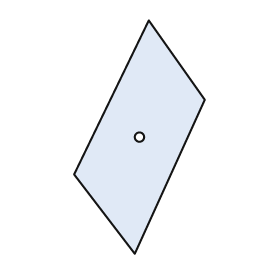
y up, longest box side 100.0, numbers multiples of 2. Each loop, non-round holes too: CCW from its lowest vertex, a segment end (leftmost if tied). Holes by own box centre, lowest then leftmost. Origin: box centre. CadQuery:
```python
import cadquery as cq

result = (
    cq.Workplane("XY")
    .moveTo(-2.0, -50.0)
    .lineTo(28.0, 16.0)
    .lineTo(4.0, 50.0)
    .lineTo(-28.0, -16.0)
    .close()
    .moveTo(0.0, 0.0)
    .circle(2.0)
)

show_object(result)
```